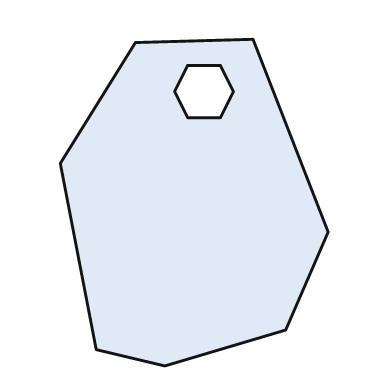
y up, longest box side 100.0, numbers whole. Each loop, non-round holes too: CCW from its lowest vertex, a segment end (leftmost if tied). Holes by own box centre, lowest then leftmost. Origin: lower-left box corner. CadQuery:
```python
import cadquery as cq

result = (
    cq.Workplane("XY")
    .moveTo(32.0, 0.0)
    .lineTo(69.0, 11.0)
    .lineTo(82.0, 41.0)
    .lineTo(59.0, 100.0)
    .lineTo(23.0, 99.0)
    .lineTo(0.0, 62.0)
    .lineTo(11.0, 5.0)
    .close()
    .moveTo(39.0, 76.0)
    .lineTo(49.0, 76.0)
    .lineTo(53.0, 84.0)
    .lineTo(49.0, 92.0)
    .lineTo(39.0, 92.0)
    .lineTo(35.0, 84.0)
    .close()
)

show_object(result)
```